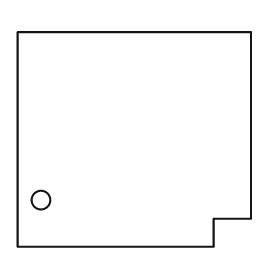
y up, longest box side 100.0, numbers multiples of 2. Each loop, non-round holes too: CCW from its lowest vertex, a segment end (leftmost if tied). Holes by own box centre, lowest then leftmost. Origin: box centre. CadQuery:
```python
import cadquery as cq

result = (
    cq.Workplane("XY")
    .moveTo(-50.0, -46.0)
    .lineTo(34.0, -46.0)
    .lineTo(34.0, -34.0)
    .lineTo(50.0, -34.0)
    .lineTo(50.0, 46.0)
    .lineTo(-50.0, 46.0)
    .close()
    .moveTo(-40.0, -26.0)
    .circle(4.0)
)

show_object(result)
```